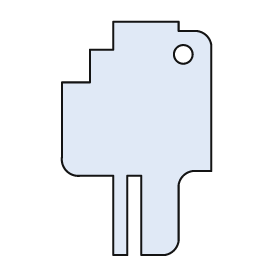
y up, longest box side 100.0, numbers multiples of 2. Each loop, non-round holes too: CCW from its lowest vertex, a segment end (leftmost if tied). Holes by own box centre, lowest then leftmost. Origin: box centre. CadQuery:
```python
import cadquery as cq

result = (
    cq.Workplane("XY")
    .moveTo(-10.0, -50.0)
    .lineTo(-4.0, -50.0)
    .lineTo(-4.0, -16.0)
    .lineTo(2.0, -16.0)
    .lineTo(2.0, -50.0)
    .lineTo(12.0, -50.0)
    .threePointArc((16.0, -48.0), (18.0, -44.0))
    .lineTo(18.0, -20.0)
    .threePointArc((20.0, -16.0), (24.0, -14.0))
    .lineTo(32.0, -14.0)
    .lineTo(32.0, 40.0)
    .threePointArc((30.0, 44.0), (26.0, 46.0))
    .lineTo(18.0, 46.0)
    .lineTo(18.0, 50.0)
    .lineTo(-10.0, 50.0)
    .lineTo(-10.0, 38.0)
    .lineTo(-20.0, 38.0)
    .lineTo(-20.0, 24.0)
    .lineTo(-32.0, 24.0)
    .lineTo(-32.0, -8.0)
    .threePointArc((-30.0, -14.0), (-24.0, -16.0))
    .lineTo(-10.0, -16.0)
    .close()
    .moveTo(20.0, 36.0)
    .circle(4.0)
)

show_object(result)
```